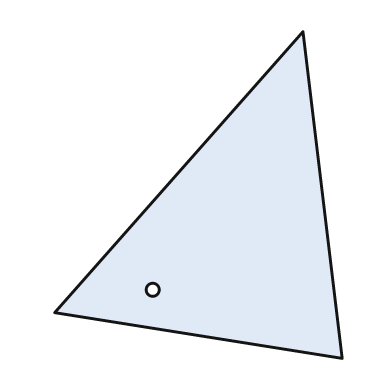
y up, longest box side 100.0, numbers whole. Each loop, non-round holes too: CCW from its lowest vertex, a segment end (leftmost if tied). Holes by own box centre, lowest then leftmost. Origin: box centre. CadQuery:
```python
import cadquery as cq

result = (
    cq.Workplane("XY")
    .moveTo(44.0, -50.0)
    .lineTo(32.0, 50.0)
    .lineTo(-44.0, -36.0)
    .close()
    .moveTo(-14.0, -29.0)
    .circle(2.0)
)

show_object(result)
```